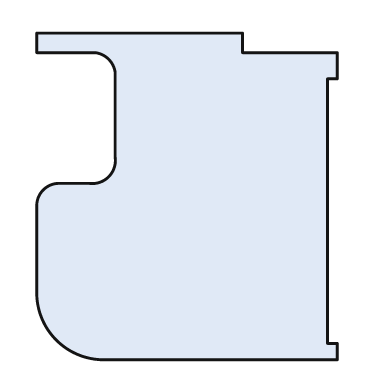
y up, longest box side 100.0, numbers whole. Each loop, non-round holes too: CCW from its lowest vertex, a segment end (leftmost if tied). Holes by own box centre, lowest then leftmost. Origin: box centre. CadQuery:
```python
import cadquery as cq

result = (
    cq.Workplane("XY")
    .moveTo(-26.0, -50.0)
    .lineTo(46.0, -50.0)
    .lineTo(46.0, -45.0)
    .lineTo(43.0, -45.0)
    .lineTo(43.0, 36.0)
    .lineTo(46.0, 36.0)
    .lineTo(46.0, 44.0)
    .lineTo(17.0, 44.0)
    .lineTo(17.0, 50.0)
    .lineTo(-46.0, 50.0)
    .lineTo(-46.0, 44.0)
    .lineTo(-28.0, 44.0)
    .threePointArc((-24.0, 42.0), (-22.0, 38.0))
    .lineTo(-22.0, 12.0)
    .threePointArc((-24.0, 6.0), (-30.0, 4.0))
    .lineTo(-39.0, 4.0)
    .threePointArc((-44.0, 2.0), (-46.0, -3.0))
    .lineTo(-46.0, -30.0)
    .threePointArc((-40.0, -44.0), (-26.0, -50.0))
    .close()
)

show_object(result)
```